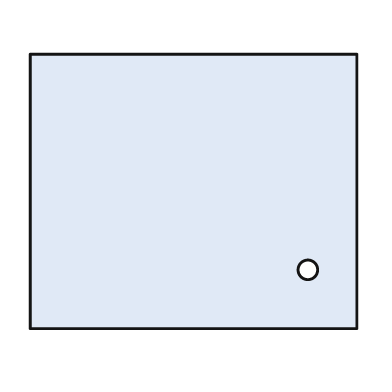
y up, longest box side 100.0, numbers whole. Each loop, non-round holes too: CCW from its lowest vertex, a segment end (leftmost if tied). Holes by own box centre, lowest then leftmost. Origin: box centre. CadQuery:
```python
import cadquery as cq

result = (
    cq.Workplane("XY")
    .moveTo(-50.0, -42.0)
    .lineTo(50.0, -42.0)
    .lineTo(50.0, 42.0)
    .lineTo(-50.0, 42.0)
    .close()
    .moveTo(35.0, -24.0)
    .circle(3.0)
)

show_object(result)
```